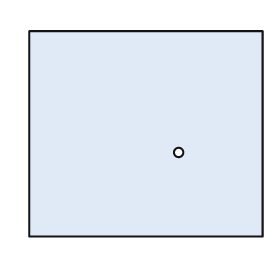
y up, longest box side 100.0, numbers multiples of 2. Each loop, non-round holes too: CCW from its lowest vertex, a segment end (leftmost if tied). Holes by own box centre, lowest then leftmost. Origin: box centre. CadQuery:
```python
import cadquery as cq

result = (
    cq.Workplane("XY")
    .moveTo(-50.0, -44.0)
    .lineTo(50.0, -44.0)
    .lineTo(50.0, 44.0)
    .lineTo(-50.0, 44.0)
    .close()
    .moveTo(14.0, -8.0)
    .circle(2.0)
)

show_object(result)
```